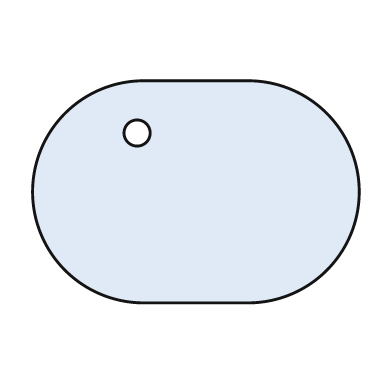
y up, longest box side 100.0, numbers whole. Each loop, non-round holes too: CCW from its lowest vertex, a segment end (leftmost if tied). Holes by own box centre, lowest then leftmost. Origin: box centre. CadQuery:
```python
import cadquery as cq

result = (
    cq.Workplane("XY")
    .moveTo(-16.0, -34.0)
    .lineTo(16.0, -34.0)
    .threePointArc((50.0, 0.0), (16.0, 34.0))
    .lineTo(-16.0, 34.0)
    .threePointArc((-50.0, 0.0), (-16.0, -34.0))
    .close()
    .moveTo(-18.0, 18.0)
    .circle(4.0)
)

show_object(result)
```